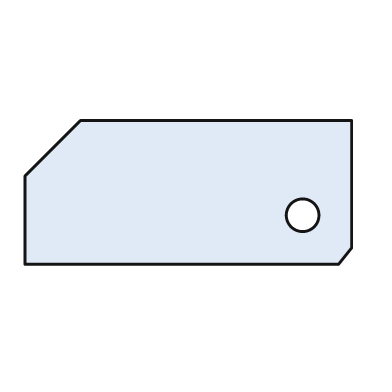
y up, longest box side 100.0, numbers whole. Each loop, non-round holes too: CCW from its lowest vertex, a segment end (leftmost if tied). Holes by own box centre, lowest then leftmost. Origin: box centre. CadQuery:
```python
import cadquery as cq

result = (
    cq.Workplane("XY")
    .moveTo(-50.0, -22.0)
    .lineTo(46.0, -22.0)
    .lineTo(50.0, -17.0)
    .lineTo(50.0, 22.0)
    .lineTo(-33.0, 22.0)
    .lineTo(-50.0, 5.0)
    .close()
    .moveTo(35.0, -7.0)
    .circle(5.0)
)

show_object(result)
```